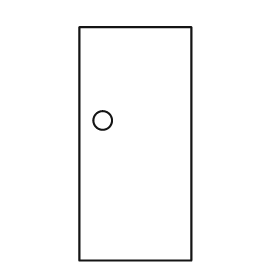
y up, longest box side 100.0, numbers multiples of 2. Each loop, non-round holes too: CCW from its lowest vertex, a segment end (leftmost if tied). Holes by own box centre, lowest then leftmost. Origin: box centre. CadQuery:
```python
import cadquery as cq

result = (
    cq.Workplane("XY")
    .moveTo(-24.0, -50.0)
    .lineTo(24.0, -50.0)
    .lineTo(24.0, 50.0)
    .lineTo(-24.0, 50.0)
    .close()
    .moveTo(-14.0, 10.0)
    .circle(4.0)
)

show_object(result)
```